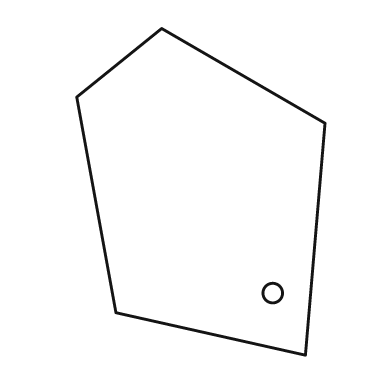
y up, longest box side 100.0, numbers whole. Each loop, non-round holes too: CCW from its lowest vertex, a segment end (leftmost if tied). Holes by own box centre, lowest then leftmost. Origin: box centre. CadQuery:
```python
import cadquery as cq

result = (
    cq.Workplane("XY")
    .moveTo(32.0, -50.0)
    .lineTo(38.0, 21.0)
    .lineTo(-12.0, 50.0)
    .lineTo(-38.0, 29.0)
    .lineTo(-26.0, -37.0)
    .close()
    .moveTo(22.0, -31.0)
    .circle(3.0)
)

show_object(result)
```